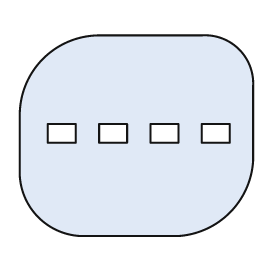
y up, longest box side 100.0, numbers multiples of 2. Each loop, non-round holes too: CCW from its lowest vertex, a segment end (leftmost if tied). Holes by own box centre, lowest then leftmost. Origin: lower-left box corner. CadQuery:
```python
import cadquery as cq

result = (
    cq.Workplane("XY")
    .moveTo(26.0, 0.0)
    .lineTo(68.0, 0.0)
    .threePointArc((90.0, 10.0), (100.0, 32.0))
    .lineTo(100.0, 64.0)
    .threePointArc((94.0, 80.0), (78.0, 86.0))
    .lineTo(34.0, 86.0)
    .threePointArc((10.0, 76.0), (0.0, 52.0))
    .lineTo(0.0, 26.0)
    .threePointArc((8.0, 8.0), (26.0, 0.0))
    .close()
    .moveTo(12.0, 40.0)
    .lineTo(24.0, 40.0)
    .lineTo(24.0, 48.0)
    .lineTo(12.0, 48.0)
    .close()
    .moveTo(34.0, 40.0)
    .lineTo(46.0, 40.0)
    .lineTo(46.0, 48.0)
    .lineTo(34.0, 48.0)
    .close()
    .moveTo(56.0, 40.0)
    .lineTo(68.0, 40.0)
    .lineTo(68.0, 48.0)
    .lineTo(56.0, 48.0)
    .close()
    .moveTo(78.0, 40.0)
    .lineTo(90.0, 40.0)
    .lineTo(90.0, 48.0)
    .lineTo(78.0, 48.0)
    .close()
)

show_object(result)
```